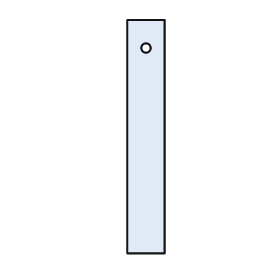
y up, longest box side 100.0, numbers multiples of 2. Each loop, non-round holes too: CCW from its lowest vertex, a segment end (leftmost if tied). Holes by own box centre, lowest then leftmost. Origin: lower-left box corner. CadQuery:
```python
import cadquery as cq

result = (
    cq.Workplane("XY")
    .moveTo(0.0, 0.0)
    .lineTo(16.0, 0.0)
    .lineTo(16.0, 100.0)
    .lineTo(0.0, 100.0)
    .close()
    .moveTo(8.0, 88.0)
    .circle(2.0)
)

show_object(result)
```